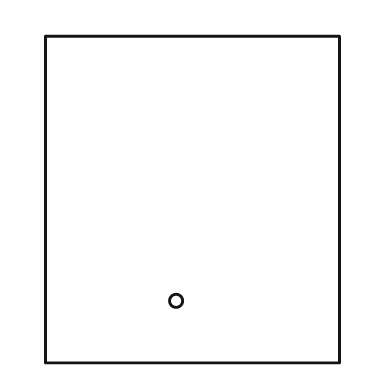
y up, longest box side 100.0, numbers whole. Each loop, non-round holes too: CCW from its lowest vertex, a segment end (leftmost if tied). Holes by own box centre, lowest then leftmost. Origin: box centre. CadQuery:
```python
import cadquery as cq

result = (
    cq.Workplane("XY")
    .moveTo(-45.0, -50.0)
    .lineTo(45.0, -50.0)
    .lineTo(45.0, 50.0)
    .lineTo(-45.0, 50.0)
    .close()
    .moveTo(-5.0, -31.0)
    .circle(2.0)
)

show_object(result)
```